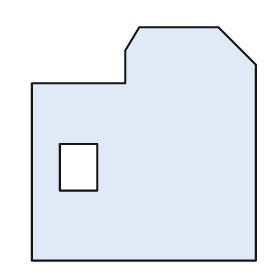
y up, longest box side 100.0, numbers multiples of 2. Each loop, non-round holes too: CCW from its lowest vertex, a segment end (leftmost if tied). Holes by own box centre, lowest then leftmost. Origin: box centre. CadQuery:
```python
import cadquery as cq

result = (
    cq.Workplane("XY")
    .moveTo(-48.0, -50.0)
    .lineTo(48.0, -50.0)
    .lineTo(48.0, 34.0)
    .lineTo(32.0, 50.0)
    .lineTo(-2.0, 50.0)
    .lineTo(-8.0, 40.0)
    .lineTo(-8.0, 26.0)
    .lineTo(-48.0, 26.0)
    .close()
    .moveTo(-36.0, -20.0)
    .lineTo(-20.0, -20.0)
    .lineTo(-20.0, 0.0)
    .lineTo(-36.0, 0.0)
    .close()
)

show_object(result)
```